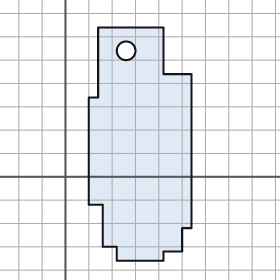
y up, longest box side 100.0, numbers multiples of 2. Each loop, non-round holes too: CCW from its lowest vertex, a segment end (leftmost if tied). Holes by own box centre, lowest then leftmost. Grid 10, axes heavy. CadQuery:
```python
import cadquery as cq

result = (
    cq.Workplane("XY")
    .moveTo(22.0, -36.0)
    .lineTo(42.0, -36.0)
    .lineTo(42.0, -32.0)
    .lineTo(50.0, -32.0)
    .lineTo(50.0, -22.0)
    .lineTo(54.0, -22.0)
    .lineTo(54.0, 44.0)
    .lineTo(42.0, 44.0)
    .lineTo(42.0, 64.0)
    .lineTo(14.0, 64.0)
    .lineTo(14.0, 34.0)
    .lineTo(10.0, 34.0)
    .lineTo(10.0, -12.0)
    .lineTo(16.0, -12.0)
    .lineTo(16.0, -30.0)
    .lineTo(22.0, -30.0)
    .close()
    .moveTo(26.0, 54.0)
    .circle(4.0)
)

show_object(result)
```